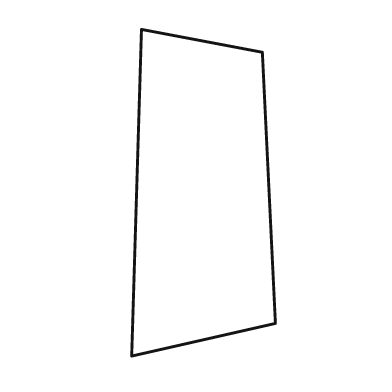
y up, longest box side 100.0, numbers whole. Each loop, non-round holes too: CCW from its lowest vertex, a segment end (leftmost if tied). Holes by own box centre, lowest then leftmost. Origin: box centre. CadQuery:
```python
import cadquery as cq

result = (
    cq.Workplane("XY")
    .moveTo(-22.0, -50.0)
    .lineTo(22.0, -40.0)
    .lineTo(18.0, 43.0)
    .lineTo(-19.0, 50.0)
    .close()
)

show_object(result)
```